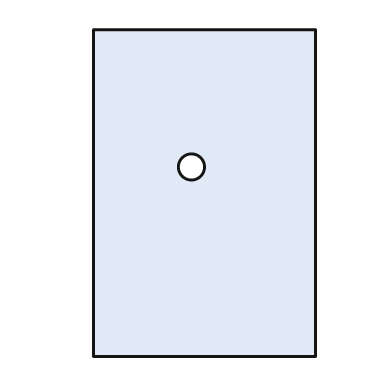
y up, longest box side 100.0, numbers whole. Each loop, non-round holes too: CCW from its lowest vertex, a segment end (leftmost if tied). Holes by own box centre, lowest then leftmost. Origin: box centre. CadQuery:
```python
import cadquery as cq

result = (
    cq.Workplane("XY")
    .moveTo(-34.0, -50.0)
    .lineTo(34.0, -50.0)
    .lineTo(34.0, 50.0)
    .lineTo(-34.0, 50.0)
    .close()
    .moveTo(-4.0, 8.0)
    .circle(4.0)
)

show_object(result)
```